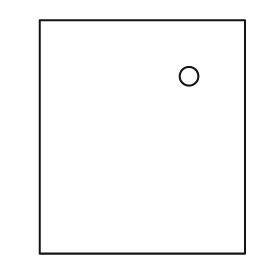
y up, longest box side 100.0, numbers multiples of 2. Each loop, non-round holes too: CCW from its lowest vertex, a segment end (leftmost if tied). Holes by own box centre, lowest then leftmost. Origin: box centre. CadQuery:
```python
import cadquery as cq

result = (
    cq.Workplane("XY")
    .moveTo(-44.0, -50.0)
    .lineTo(44.0, -50.0)
    .lineTo(44.0, 50.0)
    .lineTo(-44.0, 50.0)
    .close()
    .moveTo(20.0, 26.0)
    .circle(4.0)
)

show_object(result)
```